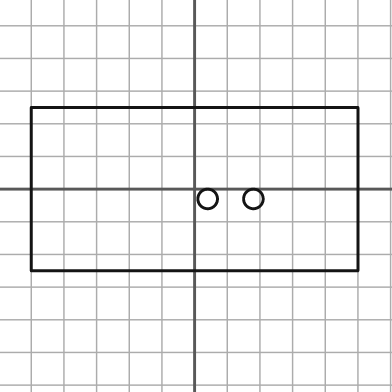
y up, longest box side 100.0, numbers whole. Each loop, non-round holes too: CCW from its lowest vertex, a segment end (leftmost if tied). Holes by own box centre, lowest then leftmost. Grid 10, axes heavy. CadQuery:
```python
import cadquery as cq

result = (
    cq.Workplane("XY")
    .moveTo(-50.0, -25.0)
    .lineTo(50.0, -25.0)
    .lineTo(50.0, 25.0)
    .lineTo(-50.0, 25.0)
    .close()
    .moveTo(4.0, -3.0)
    .circle(3.0)
    .moveTo(18.0, -3.0)
    .circle(3.0)
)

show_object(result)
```